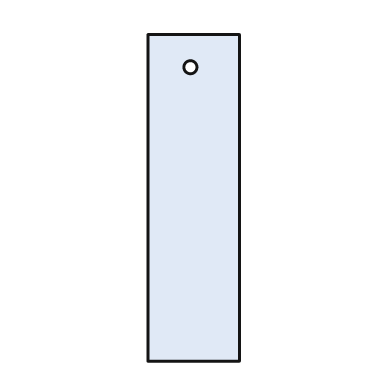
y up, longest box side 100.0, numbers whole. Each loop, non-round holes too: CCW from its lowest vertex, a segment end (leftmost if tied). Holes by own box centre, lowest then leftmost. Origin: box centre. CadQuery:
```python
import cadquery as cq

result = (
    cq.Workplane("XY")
    .moveTo(-14.0, -50.0)
    .lineTo(14.0, -50.0)
    .lineTo(14.0, 50.0)
    .lineTo(-14.0, 50.0)
    .close()
    .moveTo(-1.0, 40.0)
    .circle(2.0)
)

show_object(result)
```